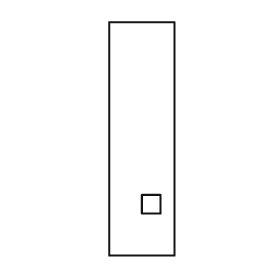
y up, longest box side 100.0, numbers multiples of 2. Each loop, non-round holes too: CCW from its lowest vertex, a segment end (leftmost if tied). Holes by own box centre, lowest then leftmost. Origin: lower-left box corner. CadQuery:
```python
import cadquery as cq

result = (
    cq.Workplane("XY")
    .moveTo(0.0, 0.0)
    .lineTo(28.0, 0.0)
    .lineTo(28.0, 100.0)
    .lineTo(0.0, 100.0)
    .close()
    .moveTo(14.0, 18.0)
    .lineTo(22.0, 18.0)
    .lineTo(22.0, 26.0)
    .lineTo(14.0, 26.0)
    .close()
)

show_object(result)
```